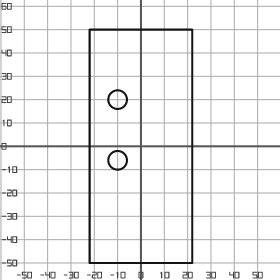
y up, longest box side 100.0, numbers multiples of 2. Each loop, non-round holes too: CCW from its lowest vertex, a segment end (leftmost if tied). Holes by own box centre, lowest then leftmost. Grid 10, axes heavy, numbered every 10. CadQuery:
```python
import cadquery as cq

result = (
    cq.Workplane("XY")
    .moveTo(-22.0, -50.0)
    .lineTo(22.0, -50.0)
    .lineTo(22.0, 50.0)
    .lineTo(-22.0, 50.0)
    .close()
    .moveTo(-10.0, -6.0)
    .circle(4.0)
    .moveTo(-10.0, 20.0)
    .circle(4.0)
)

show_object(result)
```